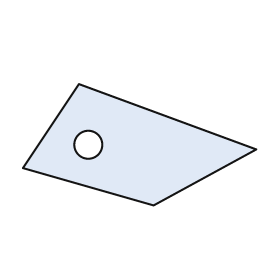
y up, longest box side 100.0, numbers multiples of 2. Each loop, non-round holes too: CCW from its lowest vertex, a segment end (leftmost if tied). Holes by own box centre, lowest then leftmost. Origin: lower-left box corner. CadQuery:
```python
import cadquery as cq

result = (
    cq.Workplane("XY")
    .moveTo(56.0, 0.0)
    .lineTo(100.0, 24.0)
    .lineTo(24.0, 52.0)
    .lineTo(0.0, 16.0)
    .close()
    .moveTo(28.0, 26.0)
    .circle(6.0)
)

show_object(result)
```